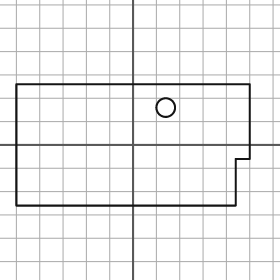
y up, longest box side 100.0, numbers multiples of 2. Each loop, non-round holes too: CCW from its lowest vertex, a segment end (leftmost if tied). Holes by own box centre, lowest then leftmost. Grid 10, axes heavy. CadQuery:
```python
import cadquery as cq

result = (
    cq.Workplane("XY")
    .moveTo(-50.0, -26.0)
    .lineTo(44.0, -26.0)
    .lineTo(44.0, -6.0)
    .lineTo(50.0, -6.0)
    .lineTo(50.0, 26.0)
    .lineTo(-50.0, 26.0)
    .close()
    .moveTo(14.0, 16.0)
    .circle(4.0)
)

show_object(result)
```